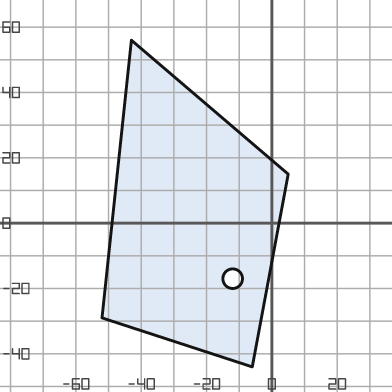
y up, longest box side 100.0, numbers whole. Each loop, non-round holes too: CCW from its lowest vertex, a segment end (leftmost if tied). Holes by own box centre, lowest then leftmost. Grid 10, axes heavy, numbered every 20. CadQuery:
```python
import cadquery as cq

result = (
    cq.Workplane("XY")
    .moveTo(-6.0, -44.0)
    .lineTo(5.0, 15.0)
    .lineTo(-43.0, 56.0)
    .lineTo(-52.0, -29.0)
    .close()
    .moveTo(-12.0, -17.0)
    .circle(3.0)
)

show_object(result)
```